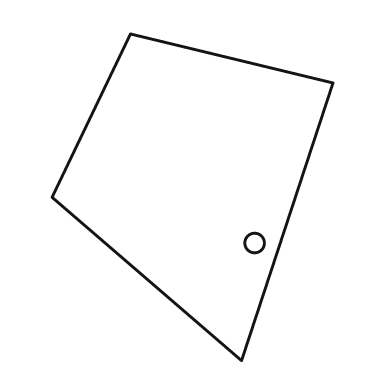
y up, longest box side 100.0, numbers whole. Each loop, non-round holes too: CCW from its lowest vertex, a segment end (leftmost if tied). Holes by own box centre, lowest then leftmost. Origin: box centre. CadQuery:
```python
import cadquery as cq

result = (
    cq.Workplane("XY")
    .moveTo(15.0, -50.0)
    .lineTo(43.0, 35.0)
    .lineTo(-19.0, 50.0)
    .lineTo(-43.0, 0.0)
    .close()
    .moveTo(19.0, -14.0)
    .circle(3.0)
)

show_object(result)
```